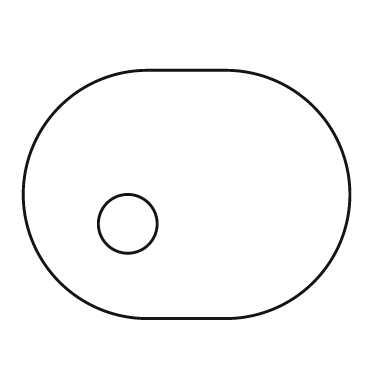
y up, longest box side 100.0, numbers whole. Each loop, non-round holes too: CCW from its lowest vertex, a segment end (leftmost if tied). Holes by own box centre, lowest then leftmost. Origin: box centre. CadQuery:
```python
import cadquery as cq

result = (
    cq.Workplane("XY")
    .moveTo(-12.0, -38.0)
    .lineTo(12.0, -38.0)
    .threePointArc((50.0, 0.0), (12.0, 38.0))
    .lineTo(-12.0, 38.0)
    .threePointArc((-50.0, 0.0), (-12.0, -38.0))
    .close()
    .moveTo(-18.0, -9.0)
    .circle(9.0)
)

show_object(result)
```